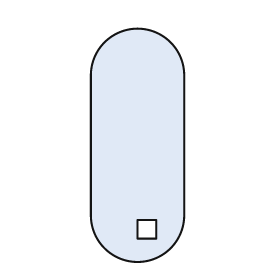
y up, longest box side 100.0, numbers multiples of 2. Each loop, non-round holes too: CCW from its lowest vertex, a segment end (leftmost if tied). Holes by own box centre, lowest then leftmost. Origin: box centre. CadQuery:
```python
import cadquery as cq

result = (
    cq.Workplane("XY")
    .moveTo(-20.0, -30.0)
    .threePointArc((0.0, -50.0), (20.0, -30.0))
    .lineTo(20.0, 30.0)
    .threePointArc((0.0, 50.0), (-20.0, 30.0))
    .close()
    .moveTo(0.0, -40.0)
    .lineTo(8.0, -40.0)
    .lineTo(8.0, -32.0)
    .lineTo(0.0, -32.0)
    .close()
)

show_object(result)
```